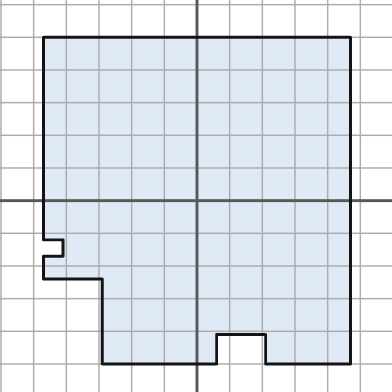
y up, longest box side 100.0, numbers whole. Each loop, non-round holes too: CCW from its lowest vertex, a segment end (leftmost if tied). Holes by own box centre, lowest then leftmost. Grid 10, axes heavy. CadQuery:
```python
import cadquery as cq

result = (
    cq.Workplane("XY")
    .moveTo(-29.0, -50.0)
    .lineTo(6.0, -50.0)
    .lineTo(6.0, -41.0)
    .lineTo(21.0, -41.0)
    .lineTo(21.0, -50.0)
    .lineTo(47.0, -50.0)
    .lineTo(47.0, 50.0)
    .lineTo(-47.0, 50.0)
    .lineTo(-47.0, -12.0)
    .lineTo(-41.0, -12.0)
    .lineTo(-41.0, -17.0)
    .lineTo(-47.0, -17.0)
    .lineTo(-47.0, -24.0)
    .lineTo(-29.0, -24.0)
    .close()
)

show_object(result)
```